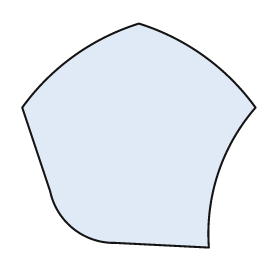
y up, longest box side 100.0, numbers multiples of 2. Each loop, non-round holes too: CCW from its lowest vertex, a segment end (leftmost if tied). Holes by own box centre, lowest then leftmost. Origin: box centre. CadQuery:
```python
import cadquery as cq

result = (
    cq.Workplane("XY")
    .moveTo(30.0, -48.0)
    .threePointArc((34.0, -16.0), (50.0, 12.0))
    .threePointArc((28.0, 34.0), (0.0, 48.0))
    .threePointArc((-28.0, 34.0), (-50.0, 12.0))
    .lineTo(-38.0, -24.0)
    .threePointArc((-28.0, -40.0), (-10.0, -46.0))
    .close()
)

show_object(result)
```